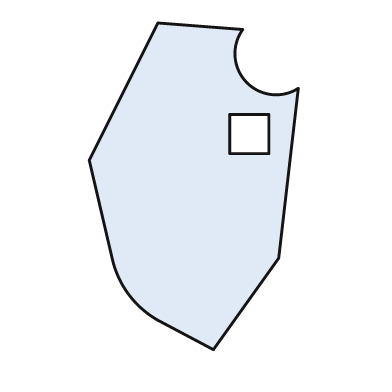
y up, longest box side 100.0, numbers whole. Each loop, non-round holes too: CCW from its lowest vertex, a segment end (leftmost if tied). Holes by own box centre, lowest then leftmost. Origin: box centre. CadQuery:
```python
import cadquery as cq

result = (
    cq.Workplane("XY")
    .moveTo(6.0, -50.0)
    .lineTo(26.0, -22.0)
    .lineTo(32.0, 30.0)
    .threePointArc((16.0, 32.0), (15.0, 48.0))
    .lineTo(-11.0, 50.0)
    .lineTo(-32.0, 8.0)
    .lineTo(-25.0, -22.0)
    .threePointArc((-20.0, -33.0), (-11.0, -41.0))
    .close()
    .moveTo(11.0, 10.0)
    .lineTo(23.0, 10.0)
    .lineTo(23.0, 22.0)
    .lineTo(11.0, 22.0)
    .close()
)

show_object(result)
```